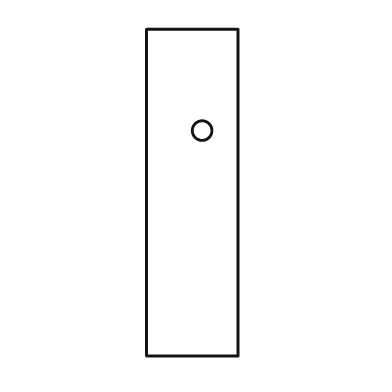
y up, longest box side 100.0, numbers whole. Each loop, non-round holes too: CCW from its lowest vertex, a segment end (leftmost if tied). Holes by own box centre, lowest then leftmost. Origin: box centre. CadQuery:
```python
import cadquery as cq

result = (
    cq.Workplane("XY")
    .moveTo(-14.0, -50.0)
    .lineTo(14.0, -50.0)
    .lineTo(14.0, 50.0)
    .lineTo(-14.0, 50.0)
    .close()
    .moveTo(3.0, 19.0)
    .circle(3.0)
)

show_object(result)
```